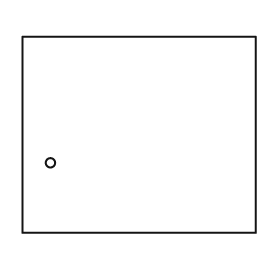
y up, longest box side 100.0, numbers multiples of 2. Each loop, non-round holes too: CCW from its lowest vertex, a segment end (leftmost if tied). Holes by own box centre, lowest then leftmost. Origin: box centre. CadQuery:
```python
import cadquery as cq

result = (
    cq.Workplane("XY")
    .moveTo(-50.0, -42.0)
    .lineTo(50.0, -42.0)
    .lineTo(50.0, 42.0)
    .lineTo(-50.0, 42.0)
    .close()
    .moveTo(-38.0, -12.0)
    .circle(2.0)
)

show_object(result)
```